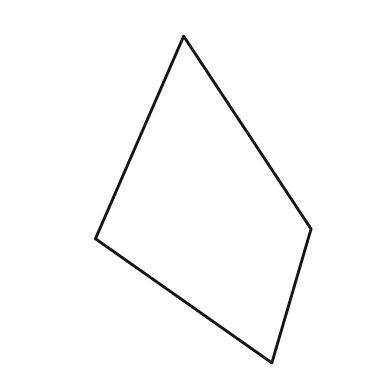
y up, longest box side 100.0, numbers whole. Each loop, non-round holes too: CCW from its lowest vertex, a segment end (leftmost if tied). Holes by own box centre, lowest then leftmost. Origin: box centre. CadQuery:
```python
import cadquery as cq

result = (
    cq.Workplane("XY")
    .moveTo(21.0, -50.0)
    .lineTo(33.0, -9.0)
    .lineTo(-6.0, 50.0)
    .lineTo(-33.0, -12.0)
    .close()
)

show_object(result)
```